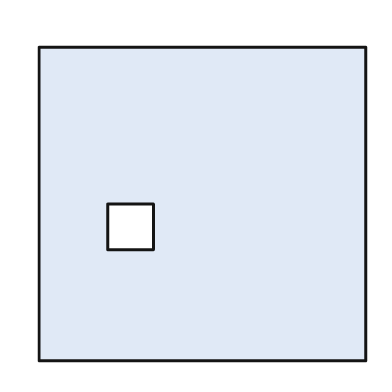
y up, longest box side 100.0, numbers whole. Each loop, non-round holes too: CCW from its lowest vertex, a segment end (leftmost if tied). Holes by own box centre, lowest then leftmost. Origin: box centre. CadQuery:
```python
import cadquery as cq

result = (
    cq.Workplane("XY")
    .moveTo(-50.0, -48.0)
    .lineTo(50.0, -48.0)
    .lineTo(50.0, 48.0)
    .lineTo(-50.0, 48.0)
    .close()
    .moveTo(-29.0, -14.0)
    .lineTo(-15.0, -14.0)
    .lineTo(-15.0, 0.0)
    .lineTo(-29.0, 0.0)
    .close()
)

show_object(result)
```